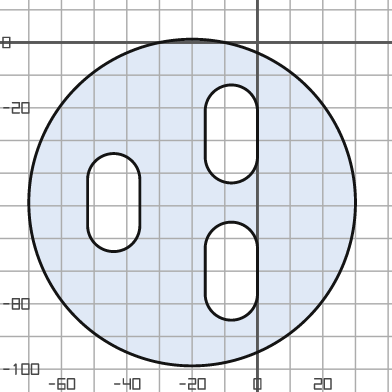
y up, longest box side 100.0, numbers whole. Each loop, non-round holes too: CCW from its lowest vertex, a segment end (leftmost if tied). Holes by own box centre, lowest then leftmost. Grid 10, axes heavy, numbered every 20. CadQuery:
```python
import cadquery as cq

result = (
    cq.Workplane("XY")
    .moveTo(-20.0, -49.0)
    .circle(50.0)
    .moveTo(-16.0, -77.0)
    .threePointArc((-8.0, -85.0), (0.0, -77.0))
    .lineTo(0.0, -63.0)
    .threePointArc((-8.0, -55.0), (-16.0, -63.0))
    .close()
    .moveTo(-52.0, -56.0)
    .threePointArc((-44.0, -64.0), (-36.0, -56.0))
    .lineTo(-36.0, -42.0)
    .threePointArc((-44.0, -34.0), (-52.0, -42.0))
    .close()
    .moveTo(-16.0, -35.0)
    .threePointArc((-8.0, -43.0), (0.0, -35.0))
    .lineTo(0.0, -21.0)
    .threePointArc((-8.0, -13.0), (-16.0, -21.0))
    .close()
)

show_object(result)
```